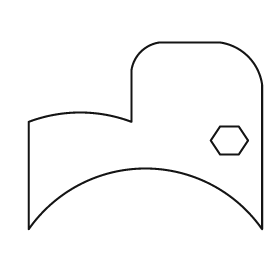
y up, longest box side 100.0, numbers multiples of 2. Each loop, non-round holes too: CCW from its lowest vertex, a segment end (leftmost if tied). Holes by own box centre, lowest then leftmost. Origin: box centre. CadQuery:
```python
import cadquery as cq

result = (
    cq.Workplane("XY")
    .moveTo(-50.0, -40.0)
    .threePointArc((0.0, -14.0), (50.0, -40.0))
    .lineTo(50.0, 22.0)
    .threePointArc((44.0, 34.0), (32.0, 40.0))
    .lineTo(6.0, 40.0)
    .threePointArc((-2.0, 36.0), (-6.0, 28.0))
    .lineTo(-6.0, 6.0)
    .threePointArc((-28.0, 10.0), (-50.0, 6.0))
    .close()
    .moveTo(32.0, -8.0)
    .lineTo(40.0, -8.0)
    .lineTo(44.0, -2.0)
    .lineTo(40.0, 4.0)
    .lineTo(32.0, 4.0)
    .lineTo(28.0, -2.0)
    .close()
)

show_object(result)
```